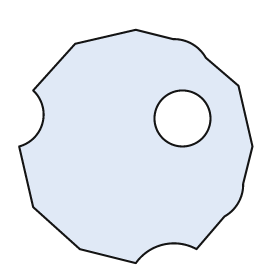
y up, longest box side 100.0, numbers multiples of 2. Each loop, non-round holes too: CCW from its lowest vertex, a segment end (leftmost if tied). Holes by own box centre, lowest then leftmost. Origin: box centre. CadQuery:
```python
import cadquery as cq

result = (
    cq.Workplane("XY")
    .moveTo(0.0, -50.0)
    .threePointArc((12.0, -42.0), (26.0, -44.0))
    .lineTo(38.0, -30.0)
    .threePointArc((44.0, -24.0), (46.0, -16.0))
    .lineTo(50.0, 0.0)
    .lineTo(44.0, 26.0)
    .lineTo(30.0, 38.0)
    .threePointArc((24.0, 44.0), (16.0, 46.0))
    .lineTo(0.0, 50.0)
    .lineTo(-26.0, 44.0)
    .lineTo(-44.0, 24.0)
    .threePointArc((-40.0, 10.0), (-50.0, 0.0))
    .lineTo(-44.0, -26.0)
    .lineTo(-24.0, -44.0)
    .close()
    .moveTo(20.0, 12.0)
    .circle(12.0)
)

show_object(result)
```